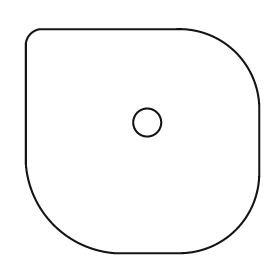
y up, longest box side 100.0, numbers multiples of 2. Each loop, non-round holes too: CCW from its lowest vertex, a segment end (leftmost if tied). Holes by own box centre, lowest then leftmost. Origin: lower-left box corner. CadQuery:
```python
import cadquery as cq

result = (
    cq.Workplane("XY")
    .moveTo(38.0, 0.0)
    .lineTo(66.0, 0.0)
    .threePointArc((90.0, 10.0), (100.0, 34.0))
    .lineTo(100.0, 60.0)
    .threePointArc((90.0, 86.0), (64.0, 96.0))
    .lineTo(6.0, 96.0)
    .threePointArc((2.0, 94.0), (0.0, 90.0))
    .lineTo(0.0, 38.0)
    .threePointArc((12.0, 12.0), (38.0, 0.0))
    .close()
    .moveTo(52.0, 56.0)
    .circle(6.0)
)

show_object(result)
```